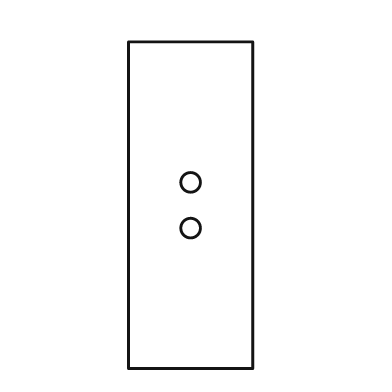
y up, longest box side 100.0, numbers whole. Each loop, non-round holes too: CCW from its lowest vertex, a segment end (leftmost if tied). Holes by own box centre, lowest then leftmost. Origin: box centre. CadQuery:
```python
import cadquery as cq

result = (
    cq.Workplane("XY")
    .moveTo(-19.0, -50.0)
    .lineTo(19.0, -50.0)
    .lineTo(19.0, 50.0)
    .lineTo(-19.0, 50.0)
    .close()
    .moveTo(0.0, -7.0)
    .circle(3.0)
    .moveTo(0.0, 7.0)
    .circle(3.0)
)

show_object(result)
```